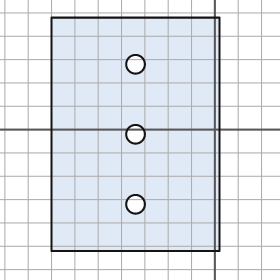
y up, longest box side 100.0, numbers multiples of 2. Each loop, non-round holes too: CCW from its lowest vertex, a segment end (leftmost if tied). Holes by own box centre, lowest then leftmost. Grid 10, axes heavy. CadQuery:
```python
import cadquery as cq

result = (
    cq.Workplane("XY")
    .moveTo(-70.0, -52.0)
    .lineTo(2.0, -52.0)
    .lineTo(2.0, 48.0)
    .lineTo(-70.0, 48.0)
    .close()
    .moveTo(-34.0, -32.0)
    .circle(4.0)
    .moveTo(-34.0, -2.0)
    .circle(4.0)
    .moveTo(-34.0, 28.0)
    .circle(4.0)
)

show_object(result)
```